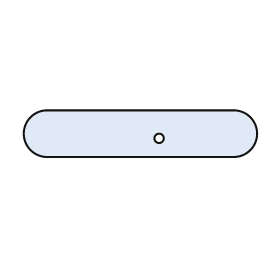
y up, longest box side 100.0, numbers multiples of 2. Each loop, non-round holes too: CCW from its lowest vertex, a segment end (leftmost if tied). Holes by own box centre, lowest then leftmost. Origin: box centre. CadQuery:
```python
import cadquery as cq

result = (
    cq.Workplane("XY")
    .moveTo(-40.0, -10.0)
    .lineTo(40.0, -10.0)
    .threePointArc((50.0, 0.0), (40.0, 10.0))
    .lineTo(-40.0, 10.0)
    .threePointArc((-50.0, 0.0), (-40.0, -10.0))
    .close()
    .moveTo(8.0, -2.0)
    .circle(2.0)
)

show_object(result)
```